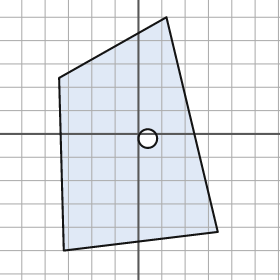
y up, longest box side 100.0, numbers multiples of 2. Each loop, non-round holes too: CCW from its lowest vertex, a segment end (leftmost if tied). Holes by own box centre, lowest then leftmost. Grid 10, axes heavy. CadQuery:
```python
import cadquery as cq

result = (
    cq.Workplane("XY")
    .moveTo(-32.0, -50.0)
    .lineTo(34.0, -42.0)
    .lineTo(12.0, 50.0)
    .lineTo(-34.0, 24.0)
    .close()
    .moveTo(4.0, -2.0)
    .circle(4.0)
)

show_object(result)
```